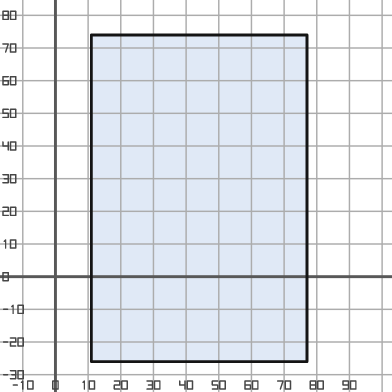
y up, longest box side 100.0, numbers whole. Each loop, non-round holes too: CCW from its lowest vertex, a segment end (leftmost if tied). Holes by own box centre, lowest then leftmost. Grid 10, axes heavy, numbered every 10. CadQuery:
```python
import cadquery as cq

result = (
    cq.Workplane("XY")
    .moveTo(11.0, -26.0)
    .lineTo(77.0, -26.0)
    .lineTo(77.0, 74.0)
    .lineTo(11.0, 74.0)
    .close()
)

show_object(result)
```